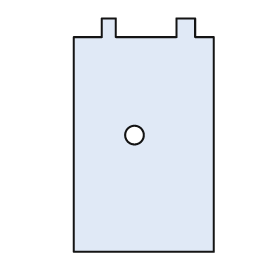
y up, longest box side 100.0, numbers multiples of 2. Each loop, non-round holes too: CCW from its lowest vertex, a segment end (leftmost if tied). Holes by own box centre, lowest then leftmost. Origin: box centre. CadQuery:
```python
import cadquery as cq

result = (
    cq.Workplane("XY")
    .moveTo(-30.0, -50.0)
    .lineTo(30.0, -50.0)
    .lineTo(30.0, 42.0)
    .lineTo(22.0, 42.0)
    .lineTo(22.0, 50.0)
    .lineTo(14.0, 50.0)
    .lineTo(14.0, 42.0)
    .lineTo(-12.0, 42.0)
    .lineTo(-12.0, 50.0)
    .lineTo(-18.0, 50.0)
    .lineTo(-18.0, 42.0)
    .lineTo(-30.0, 42.0)
    .close()
    .moveTo(-4.0, 0.0)
    .circle(4.0)
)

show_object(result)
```